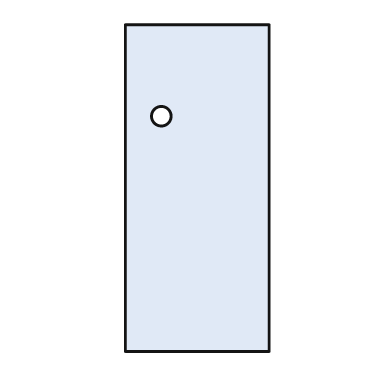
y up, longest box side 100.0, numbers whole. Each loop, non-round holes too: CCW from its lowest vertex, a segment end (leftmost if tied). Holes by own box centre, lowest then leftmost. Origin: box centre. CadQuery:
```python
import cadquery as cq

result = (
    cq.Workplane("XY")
    .moveTo(-22.0, -50.0)
    .lineTo(22.0, -50.0)
    .lineTo(22.0, 50.0)
    .lineTo(-22.0, 50.0)
    .close()
    .moveTo(-11.0, 22.0)
    .circle(3.0)
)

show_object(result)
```